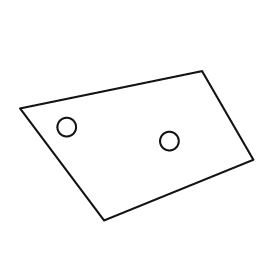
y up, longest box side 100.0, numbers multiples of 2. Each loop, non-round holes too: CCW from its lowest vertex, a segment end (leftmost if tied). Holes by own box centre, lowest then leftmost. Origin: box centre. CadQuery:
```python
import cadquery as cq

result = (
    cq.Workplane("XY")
    .moveTo(-14.0, -32.0)
    .lineTo(50.0, -6.0)
    .lineTo(28.0, 32.0)
    .lineTo(-50.0, 16.0)
    .close()
    .moveTo(14.0, 2.0)
    .circle(4.0)
    .moveTo(-30.0, 8.0)
    .circle(4.0)
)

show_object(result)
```